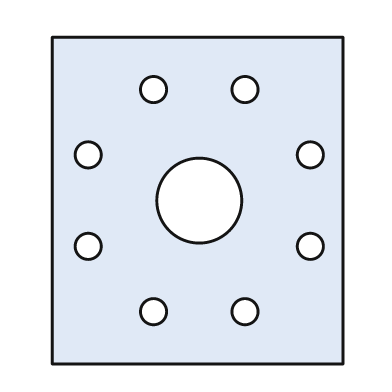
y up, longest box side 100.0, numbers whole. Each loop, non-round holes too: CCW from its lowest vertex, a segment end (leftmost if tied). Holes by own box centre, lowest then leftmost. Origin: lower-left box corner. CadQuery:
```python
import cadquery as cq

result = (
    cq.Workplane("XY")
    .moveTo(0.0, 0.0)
    .lineTo(89.0, 0.0)
    .lineTo(89.0, 100.0)
    .lineTo(0.0, 100.0)
    .close()
    .moveTo(31.0, 16.0)
    .circle(4.0)
    .moveTo(59.0, 16.0)
    .circle(4.0)
    .moveTo(11.0, 36.0)
    .circle(4.0)
    .moveTo(79.0, 36.0)
    .circle(4.0)
    .moveTo(45.0, 50.0)
    .circle(13.0)
    .moveTo(11.0, 64.0)
    .circle(4.0)
    .moveTo(79.0, 64.0)
    .circle(4.0)
    .moveTo(31.0, 84.0)
    .circle(4.0)
    .moveTo(59.0, 84.0)
    .circle(4.0)
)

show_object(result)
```